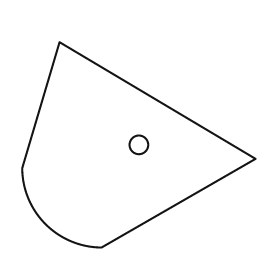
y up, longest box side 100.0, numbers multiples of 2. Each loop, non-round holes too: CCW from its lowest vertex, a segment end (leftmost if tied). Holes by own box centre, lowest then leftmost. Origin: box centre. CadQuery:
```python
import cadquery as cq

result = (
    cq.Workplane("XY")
    .moveTo(-16.0, -44.0)
    .lineTo(50.0, -6.0)
    .lineTo(-34.0, 44.0)
    .lineTo(-50.0, -10.0)
    .threePointArc((-40.0, -34.0), (-16.0, -44.0))
    .close()
    .moveTo(0.0, 0.0)
    .circle(4.0)
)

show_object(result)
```